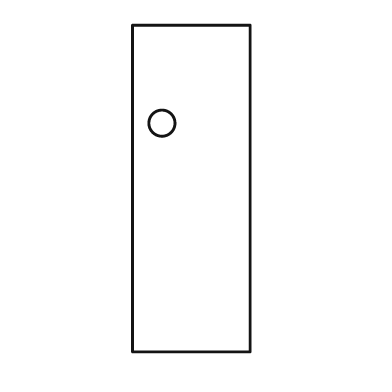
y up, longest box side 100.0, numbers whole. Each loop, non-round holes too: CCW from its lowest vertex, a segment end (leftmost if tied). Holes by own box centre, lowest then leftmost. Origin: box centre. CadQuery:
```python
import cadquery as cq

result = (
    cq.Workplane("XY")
    .moveTo(-18.0, -50.0)
    .lineTo(18.0, -50.0)
    .lineTo(18.0, 50.0)
    .lineTo(-18.0, 50.0)
    .close()
    .moveTo(-9.0, 20.0)
    .circle(4.0)
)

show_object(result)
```